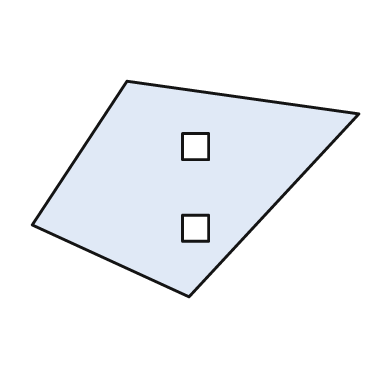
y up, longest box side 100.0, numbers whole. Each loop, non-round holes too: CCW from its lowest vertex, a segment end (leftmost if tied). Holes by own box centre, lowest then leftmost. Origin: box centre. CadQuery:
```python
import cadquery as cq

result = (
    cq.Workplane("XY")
    .moveTo(-2.0, -33.0)
    .lineTo(50.0, 23.0)
    .lineTo(-21.0, 33.0)
    .lineTo(-50.0, -11.0)
    .close()
    .moveTo(-4.0, -16.0)
    .lineTo(4.0, -16.0)
    .lineTo(4.0, -8.0)
    .lineTo(-4.0, -8.0)
    .close()
    .moveTo(-4.0, 9.0)
    .lineTo(4.0, 9.0)
    .lineTo(4.0, 17.0)
    .lineTo(-4.0, 17.0)
    .close()
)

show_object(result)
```